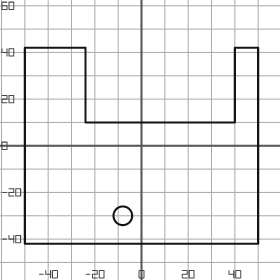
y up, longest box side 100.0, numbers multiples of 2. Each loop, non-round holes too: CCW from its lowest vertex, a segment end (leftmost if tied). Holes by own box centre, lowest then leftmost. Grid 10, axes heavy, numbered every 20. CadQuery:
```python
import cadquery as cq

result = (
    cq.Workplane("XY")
    .moveTo(-50.0, -42.0)
    .lineTo(50.0, -42.0)
    .lineTo(50.0, 42.0)
    .lineTo(40.0, 42.0)
    .lineTo(40.0, 10.0)
    .lineTo(-24.0, 10.0)
    .lineTo(-24.0, 42.0)
    .lineTo(-50.0, 42.0)
    .close()
    .moveTo(-8.0, -30.0)
    .circle(4.0)
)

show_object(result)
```